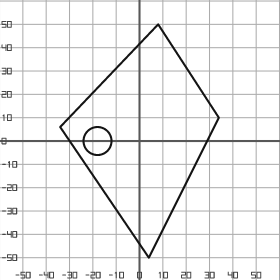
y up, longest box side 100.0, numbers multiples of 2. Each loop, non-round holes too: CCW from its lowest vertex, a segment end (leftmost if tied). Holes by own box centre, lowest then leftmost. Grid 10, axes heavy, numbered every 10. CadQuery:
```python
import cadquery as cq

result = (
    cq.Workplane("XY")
    .moveTo(4.0, -50.0)
    .lineTo(34.0, 10.0)
    .lineTo(8.0, 50.0)
    .lineTo(-34.0, 6.0)
    .close()
    .moveTo(-18.0, 0.0)
    .circle(6.0)
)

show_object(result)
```